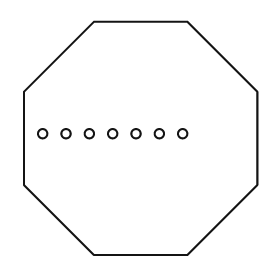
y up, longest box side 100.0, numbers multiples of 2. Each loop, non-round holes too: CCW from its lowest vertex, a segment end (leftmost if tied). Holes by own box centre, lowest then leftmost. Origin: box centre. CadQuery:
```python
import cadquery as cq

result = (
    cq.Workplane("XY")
    .moveTo(-20.0, -50.0)
    .lineTo(20.0, -50.0)
    .lineTo(50.0, -20.0)
    .lineTo(50.0, 20.0)
    .lineTo(20.0, 50.0)
    .lineTo(-20.0, 50.0)
    .lineTo(-50.0, 20.0)
    .lineTo(-50.0, -20.0)
    .close()
    .moveTo(-42.0, 2.0)
    .circle(2.0)
    .moveTo(-32.0, 2.0)
    .circle(2.0)
    .moveTo(-22.0, 2.0)
    .circle(2.0)
    .moveTo(-12.0, 2.0)
    .circle(2.0)
    .moveTo(-2.0, 2.0)
    .circle(2.0)
    .moveTo(8.0, 2.0)
    .circle(2.0)
    .moveTo(18.0, 2.0)
    .circle(2.0)
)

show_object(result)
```